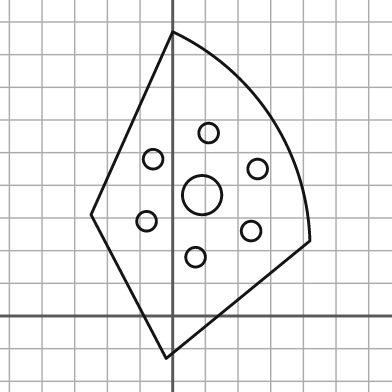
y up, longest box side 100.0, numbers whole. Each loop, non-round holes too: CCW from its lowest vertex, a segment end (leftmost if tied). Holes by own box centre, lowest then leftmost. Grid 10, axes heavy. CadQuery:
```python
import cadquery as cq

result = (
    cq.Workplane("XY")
    .moveTo(-2.0, -13.0)
    .lineTo(42.0, 23.0)
    .threePointArc((30.0, 61.0), (0.0, 87.0))
    .lineTo(-25.0, 31.0)
    .close()
    .moveTo(7.0, 18.0)
    .circle(3.0)
    .moveTo(24.0, 26.0)
    .circle(3.0)
    .moveTo(-8.0, 29.0)
    .circle(3.0)
    .moveTo(9.0, 37.0)
    .circle(6.0)
    .moveTo(26.0, 45.0)
    .circle(3.0)
    .moveTo(-6.0, 48.0)
    .circle(3.0)
    .moveTo(11.0, 56.0)
    .circle(3.0)
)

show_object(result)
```